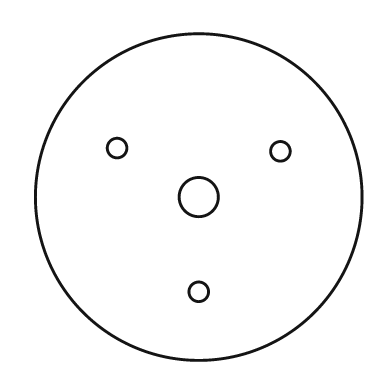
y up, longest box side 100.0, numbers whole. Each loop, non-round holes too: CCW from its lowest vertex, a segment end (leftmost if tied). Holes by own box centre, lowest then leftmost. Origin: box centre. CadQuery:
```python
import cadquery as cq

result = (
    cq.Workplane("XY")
    .moveTo(0.0, 0.0)
    .circle(50.0)
    .moveTo(0.0, -29.0)
    .circle(3.0)
    .moveTo(0.0, 0.0)
    .circle(6.0)
    .moveTo(25.0, 14.0)
    .circle(3.0)
    .moveTo(-25.0, 15.0)
    .circle(3.0)
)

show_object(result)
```